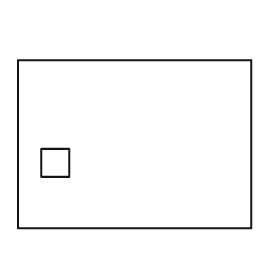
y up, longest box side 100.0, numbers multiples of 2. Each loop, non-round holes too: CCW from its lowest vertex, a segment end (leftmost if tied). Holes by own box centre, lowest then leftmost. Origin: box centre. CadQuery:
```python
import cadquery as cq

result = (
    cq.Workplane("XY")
    .moveTo(-50.0, -36.0)
    .lineTo(50.0, -36.0)
    .lineTo(50.0, 36.0)
    .lineTo(-50.0, 36.0)
    .close()
    .moveTo(-40.0, -14.0)
    .lineTo(-28.0, -14.0)
    .lineTo(-28.0, -2.0)
    .lineTo(-40.0, -2.0)
    .close()
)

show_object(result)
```